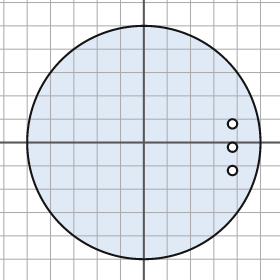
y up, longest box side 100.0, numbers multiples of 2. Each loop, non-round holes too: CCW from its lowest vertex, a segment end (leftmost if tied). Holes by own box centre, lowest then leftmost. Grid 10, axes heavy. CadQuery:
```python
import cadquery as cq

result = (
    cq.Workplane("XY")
    .moveTo(0.0, 0.0)
    .circle(50.0)
    .moveTo(38.0, -12.0)
    .circle(2.0)
    .moveTo(38.0, -2.0)
    .circle(2.0)
    .moveTo(38.0, 8.0)
    .circle(2.0)
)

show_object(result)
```